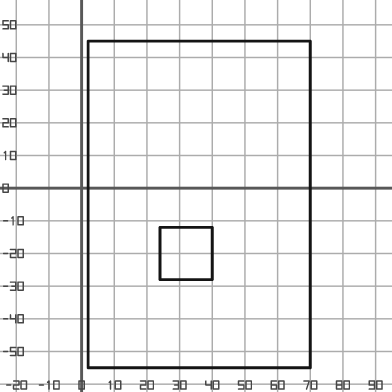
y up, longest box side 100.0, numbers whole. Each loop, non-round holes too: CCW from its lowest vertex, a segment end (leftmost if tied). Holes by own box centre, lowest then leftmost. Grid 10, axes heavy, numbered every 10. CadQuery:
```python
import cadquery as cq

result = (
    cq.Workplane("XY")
    .moveTo(2.0, -55.0)
    .lineTo(70.0, -55.0)
    .lineTo(70.0, 45.0)
    .lineTo(2.0, 45.0)
    .close()
    .moveTo(24.0, -28.0)
    .lineTo(40.0, -28.0)
    .lineTo(40.0, -12.0)
    .lineTo(24.0, -12.0)
    .close()
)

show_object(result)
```